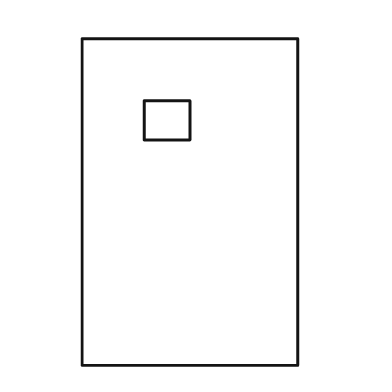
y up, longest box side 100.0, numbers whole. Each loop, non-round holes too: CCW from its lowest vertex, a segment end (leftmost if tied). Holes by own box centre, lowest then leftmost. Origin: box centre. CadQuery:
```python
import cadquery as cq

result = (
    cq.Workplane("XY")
    .moveTo(-33.0, -50.0)
    .lineTo(33.0, -50.0)
    .lineTo(33.0, 50.0)
    .lineTo(-33.0, 50.0)
    .close()
    .moveTo(-14.0, 19.0)
    .lineTo(0.0, 19.0)
    .lineTo(0.0, 31.0)
    .lineTo(-14.0, 31.0)
    .close()
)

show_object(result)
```